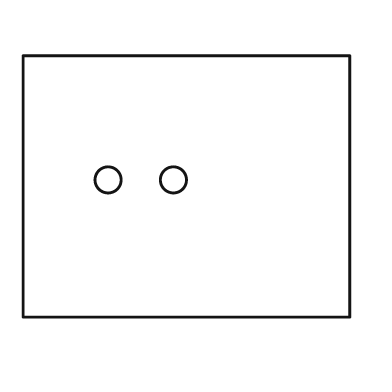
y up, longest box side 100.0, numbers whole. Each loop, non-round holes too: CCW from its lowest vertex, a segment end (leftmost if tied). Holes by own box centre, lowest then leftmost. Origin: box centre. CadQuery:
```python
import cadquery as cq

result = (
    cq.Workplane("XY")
    .moveTo(-50.0, -40.0)
    .lineTo(50.0, -40.0)
    .lineTo(50.0, 40.0)
    .lineTo(-50.0, 40.0)
    .close()
    .moveTo(-24.0, 2.0)
    .circle(4.0)
    .moveTo(-4.0, 2.0)
    .circle(4.0)
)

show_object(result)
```